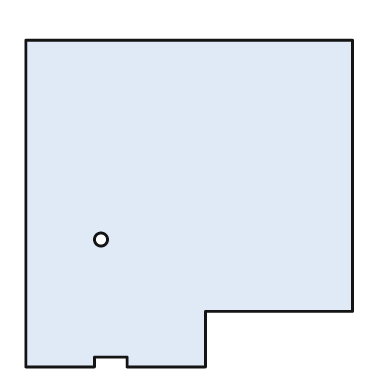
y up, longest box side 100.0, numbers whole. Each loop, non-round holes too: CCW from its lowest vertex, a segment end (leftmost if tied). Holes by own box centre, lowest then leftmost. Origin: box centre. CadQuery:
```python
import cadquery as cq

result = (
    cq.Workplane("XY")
    .moveTo(-50.0, -50.0)
    .lineTo(-29.0, -50.0)
    .lineTo(-29.0, -47.0)
    .lineTo(-19.0, -47.0)
    .lineTo(-19.0, -50.0)
    .lineTo(5.0, -50.0)
    .lineTo(5.0, -33.0)
    .lineTo(50.0, -33.0)
    .lineTo(50.0, 50.0)
    .lineTo(-50.0, 50.0)
    .close()
    .moveTo(-27.0, -11.0)
    .circle(2.0)
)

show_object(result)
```